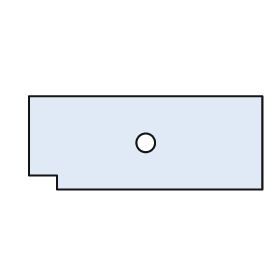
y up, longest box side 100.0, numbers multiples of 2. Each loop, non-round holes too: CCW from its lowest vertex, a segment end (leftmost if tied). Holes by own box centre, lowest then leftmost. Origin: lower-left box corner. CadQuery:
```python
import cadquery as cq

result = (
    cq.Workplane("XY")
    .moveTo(12.0, 0.0)
    .lineTo(100.0, 0.0)
    .lineTo(100.0, 40.0)
    .lineTo(0.0, 40.0)
    .lineTo(0.0, 6.0)
    .lineTo(12.0, 6.0)
    .close()
    .moveTo(50.0, 20.0)
    .circle(4.0)
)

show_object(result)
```